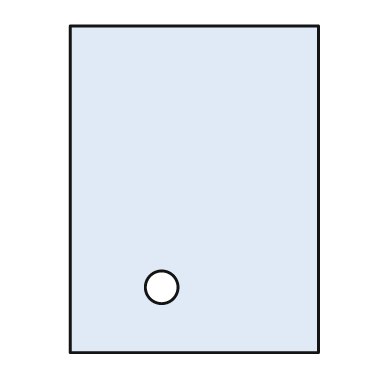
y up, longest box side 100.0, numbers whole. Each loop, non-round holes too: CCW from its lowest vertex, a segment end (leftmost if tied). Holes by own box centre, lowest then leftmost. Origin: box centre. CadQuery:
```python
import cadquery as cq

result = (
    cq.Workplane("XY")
    .moveTo(-38.0, -50.0)
    .lineTo(38.0, -50.0)
    .lineTo(38.0, 50.0)
    .lineTo(-38.0, 50.0)
    .close()
    .moveTo(-10.0, -30.0)
    .circle(5.0)
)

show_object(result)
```